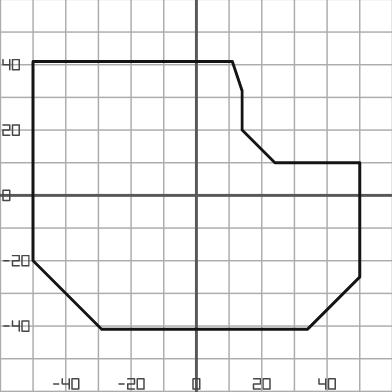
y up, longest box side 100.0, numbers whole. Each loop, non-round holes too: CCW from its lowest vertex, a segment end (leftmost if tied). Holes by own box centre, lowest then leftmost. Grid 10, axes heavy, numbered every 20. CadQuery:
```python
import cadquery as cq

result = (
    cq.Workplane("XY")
    .moveTo(-29.0, -41.0)
    .lineTo(34.0, -41.0)
    .lineTo(50.0, -25.0)
    .lineTo(50.0, 10.0)
    .lineTo(24.0, 10.0)
    .lineTo(14.0, 20.0)
    .lineTo(14.0, 32.0)
    .lineTo(11.0, 41.0)
    .lineTo(-50.0, 41.0)
    .lineTo(-50.0, -20.0)
    .close()
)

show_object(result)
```